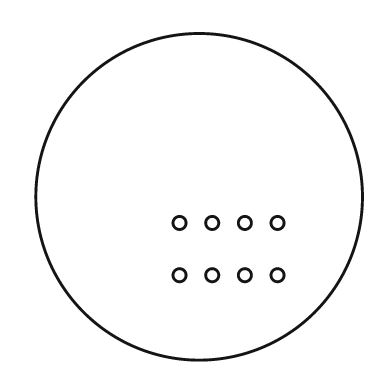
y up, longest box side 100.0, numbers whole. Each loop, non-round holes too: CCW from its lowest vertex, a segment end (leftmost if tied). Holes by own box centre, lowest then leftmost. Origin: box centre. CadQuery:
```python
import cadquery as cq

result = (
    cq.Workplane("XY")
    .moveTo(0.0, 0.0)
    .circle(50.0)
    .moveTo(-6.0, -24.0)
    .circle(2.0)
    .moveTo(4.0, -24.0)
    .circle(2.0)
    .moveTo(14.0, -24.0)
    .circle(2.0)
    .moveTo(24.0, -24.0)
    .circle(2.0)
    .moveTo(-6.0, -8.0)
    .circle(2.0)
    .moveTo(4.0, -8.0)
    .circle(2.0)
    .moveTo(14.0, -8.0)
    .circle(2.0)
    .moveTo(24.0, -8.0)
    .circle(2.0)
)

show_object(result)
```